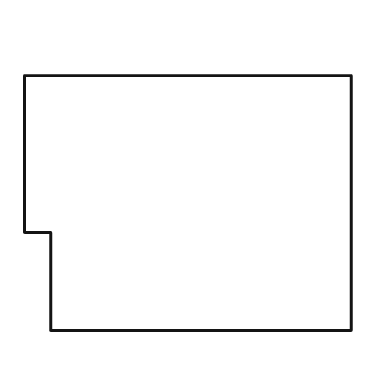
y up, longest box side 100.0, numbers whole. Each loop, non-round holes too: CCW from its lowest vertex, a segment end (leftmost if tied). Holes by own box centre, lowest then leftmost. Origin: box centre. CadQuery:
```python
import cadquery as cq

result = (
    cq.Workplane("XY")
    .moveTo(-42.0, -39.0)
    .lineTo(50.0, -39.0)
    .lineTo(50.0, 39.0)
    .lineTo(-50.0, 39.0)
    .lineTo(-50.0, -9.0)
    .lineTo(-42.0, -9.0)
    .close()
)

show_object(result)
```